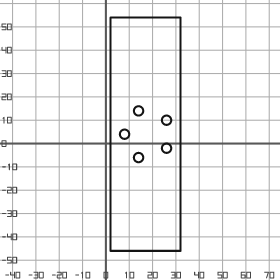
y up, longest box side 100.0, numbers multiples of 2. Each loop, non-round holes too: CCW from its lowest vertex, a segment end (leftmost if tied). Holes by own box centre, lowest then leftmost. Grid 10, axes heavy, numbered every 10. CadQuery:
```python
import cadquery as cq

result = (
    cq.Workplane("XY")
    .moveTo(2.0, -46.0)
    .lineTo(32.0, -46.0)
    .lineTo(32.0, 54.0)
    .lineTo(2.0, 54.0)
    .close()
    .moveTo(14.0, -6.0)
    .circle(2.0)
    .moveTo(26.0, -2.0)
    .circle(2.0)
    .moveTo(8.0, 4.0)
    .circle(2.0)
    .moveTo(26.0, 10.0)
    .circle(2.0)
    .moveTo(14.0, 14.0)
    .circle(2.0)
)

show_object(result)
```